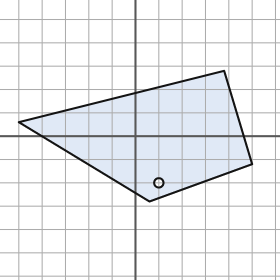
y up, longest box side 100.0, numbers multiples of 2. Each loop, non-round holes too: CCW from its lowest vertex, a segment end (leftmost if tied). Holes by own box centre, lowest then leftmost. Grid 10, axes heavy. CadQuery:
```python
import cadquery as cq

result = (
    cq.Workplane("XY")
    .moveTo(6.0, -28.0)
    .lineTo(50.0, -12.0)
    .lineTo(38.0, 28.0)
    .lineTo(-50.0, 6.0)
    .close()
    .moveTo(10.0, -20.0)
    .circle(2.0)
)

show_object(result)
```